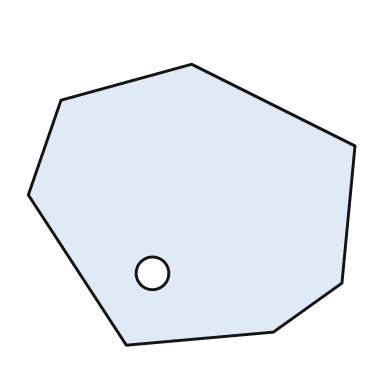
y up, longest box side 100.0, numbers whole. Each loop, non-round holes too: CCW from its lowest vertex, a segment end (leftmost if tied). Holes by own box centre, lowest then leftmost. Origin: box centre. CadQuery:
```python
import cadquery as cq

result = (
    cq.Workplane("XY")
    .moveTo(-20.0, -43.0)
    .lineTo(25.0, -39.0)
    .lineTo(46.0, -24.0)
    .lineTo(50.0, 18.0)
    .lineTo(0.0, 43.0)
    .lineTo(-40.0, 32.0)
    .lineTo(-50.0, 3.0)
    .close()
    .moveTo(-12.0, -21.0)
    .circle(5.0)
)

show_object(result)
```